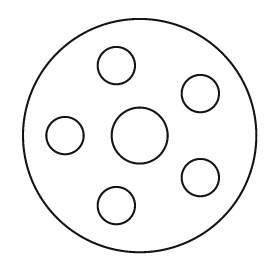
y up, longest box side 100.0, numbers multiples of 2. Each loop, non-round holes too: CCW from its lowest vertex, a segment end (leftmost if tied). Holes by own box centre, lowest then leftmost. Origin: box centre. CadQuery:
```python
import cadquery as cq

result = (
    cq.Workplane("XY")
    .moveTo(0.0, 0.0)
    .circle(50.0)
    .moveTo(-10.0, -30.0)
    .circle(8.0)
    .moveTo(26.0, -18.0)
    .circle(8.0)
    .moveTo(-32.0, 0.0)
    .circle(8.0)
    .moveTo(0.0, 0.0)
    .circle(12.0)
    .moveTo(26.0, 18.0)
    .circle(8.0)
    .moveTo(-10.0, 30.0)
    .circle(8.0)
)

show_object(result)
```